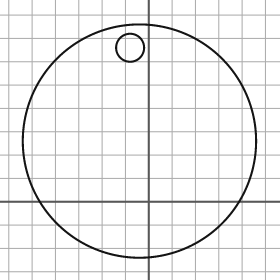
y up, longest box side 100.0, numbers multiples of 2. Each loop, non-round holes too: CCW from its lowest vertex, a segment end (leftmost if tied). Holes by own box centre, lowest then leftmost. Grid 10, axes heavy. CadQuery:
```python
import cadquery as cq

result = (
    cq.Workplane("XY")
    .moveTo(-4.0, 26.0)
    .circle(50.0)
    .moveTo(-8.0, 66.0)
    .circle(6.0)
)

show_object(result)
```